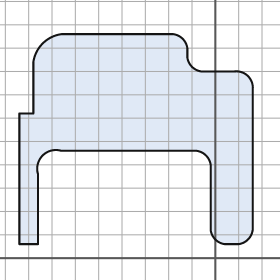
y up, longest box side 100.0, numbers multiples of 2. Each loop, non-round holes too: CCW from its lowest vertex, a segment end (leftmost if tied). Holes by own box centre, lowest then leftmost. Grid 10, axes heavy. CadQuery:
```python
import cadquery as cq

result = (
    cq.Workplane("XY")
    .moveTo(-84.0, 6.0)
    .lineTo(-76.0, 6.0)
    .lineTo(-76.0, 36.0)
    .threePointArc((-74.0, 44.0), (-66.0, 46.0))
    .lineTo(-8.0, 46.0)
    .threePointArc((-4.0, 44.0), (-2.0, 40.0))
    .lineTo(-2.0, 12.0)
    .threePointArc((0.0, 8.0), (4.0, 6.0))
    .lineTo(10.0, 6.0)
    .threePointArc((14.0, 8.0), (16.0, 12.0))
    .lineTo(16.0, 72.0)
    .threePointArc((14.0, 78.0), (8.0, 80.0))
    .lineTo(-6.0, 80.0)
    .threePointArc((-10.0, 82.0), (-12.0, 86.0))
    .lineTo(-12.0, 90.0)
    .threePointArc((-14.0, 94.0), (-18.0, 96.0))
    .lineTo(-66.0, 96.0)
    .threePointArc((-74.0, 92.0), (-78.0, 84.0))
    .lineTo(-78.0, 62.0)
    .lineTo(-84.0, 62.0)
    .close()
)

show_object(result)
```